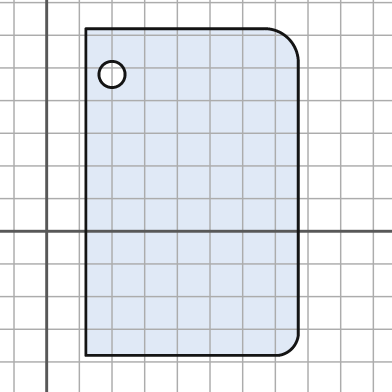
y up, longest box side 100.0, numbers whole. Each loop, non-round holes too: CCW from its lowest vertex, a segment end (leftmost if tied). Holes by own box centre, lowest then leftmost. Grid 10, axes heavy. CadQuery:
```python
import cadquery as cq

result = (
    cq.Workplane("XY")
    .moveTo(12.0, -38.0)
    .lineTo(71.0, -38.0)
    .threePointArc((75.0, -36.0), (77.0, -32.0))
    .lineTo(77.0, 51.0)
    .threePointArc((74.0, 59.0), (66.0, 62.0))
    .lineTo(12.0, 62.0)
    .close()
    .moveTo(20.0, 48.0)
    .circle(4.0)
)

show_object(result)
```